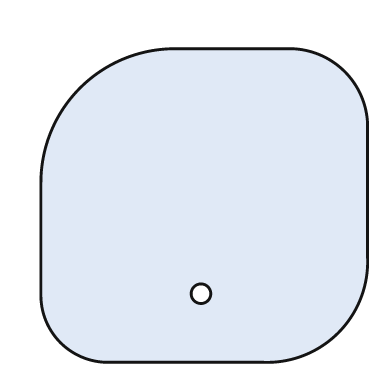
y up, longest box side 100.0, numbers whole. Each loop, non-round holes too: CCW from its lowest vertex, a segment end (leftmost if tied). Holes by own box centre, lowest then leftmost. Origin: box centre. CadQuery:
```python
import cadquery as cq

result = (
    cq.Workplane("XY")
    .moveTo(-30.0, -48.0)
    .lineTo(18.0, -48.0)
    .threePointArc((41.0, -39.0), (50.0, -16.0))
    .lineTo(50.0, 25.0)
    .threePointArc((43.0, 41.0), (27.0, 48.0))
    .lineTo(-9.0, 48.0)
    .threePointArc((-38.0, 36.0), (-50.0, 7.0))
    .lineTo(-50.0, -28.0)
    .threePointArc((-44.0, -42.0), (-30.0, -48.0))
    .close()
    .moveTo(-1.0, -27.0)
    .circle(3.0)
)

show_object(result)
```